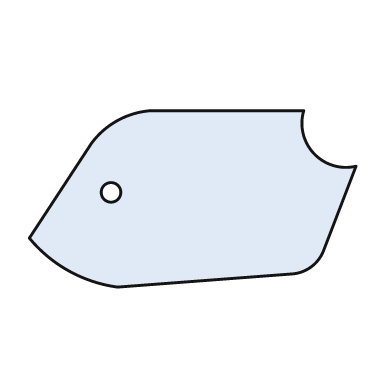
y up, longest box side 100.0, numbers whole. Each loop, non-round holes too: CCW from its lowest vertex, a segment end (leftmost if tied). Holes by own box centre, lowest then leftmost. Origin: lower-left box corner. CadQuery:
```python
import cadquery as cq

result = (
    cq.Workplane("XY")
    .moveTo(27.0, 0.0)
    .lineTo(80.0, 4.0)
    .threePointArc((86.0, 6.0), (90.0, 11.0))
    .lineTo(100.0, 37.0)
    .threePointArc((87.0, 41.0), (84.0, 54.0))
    .lineTo(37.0, 54.0)
    .threePointArc((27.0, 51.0), (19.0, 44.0))
    .lineTo(0.0, 15.0)
    .threePointArc((12.0, 5.0), (27.0, 0.0))
    .close()
    .moveTo(25.0, 29.0)
    .circle(3.0)
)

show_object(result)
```